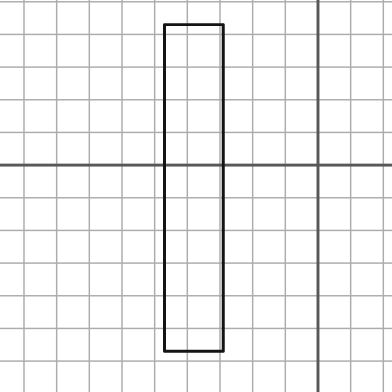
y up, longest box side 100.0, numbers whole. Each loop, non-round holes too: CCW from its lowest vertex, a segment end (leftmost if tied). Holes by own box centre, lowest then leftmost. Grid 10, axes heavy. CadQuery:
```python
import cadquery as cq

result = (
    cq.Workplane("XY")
    .moveTo(-47.0, -57.0)
    .lineTo(-29.0, -57.0)
    .lineTo(-29.0, 43.0)
    .lineTo(-47.0, 43.0)
    .close()
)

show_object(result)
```